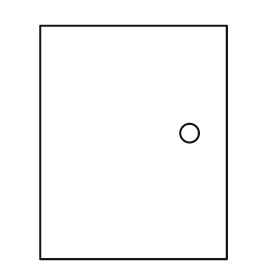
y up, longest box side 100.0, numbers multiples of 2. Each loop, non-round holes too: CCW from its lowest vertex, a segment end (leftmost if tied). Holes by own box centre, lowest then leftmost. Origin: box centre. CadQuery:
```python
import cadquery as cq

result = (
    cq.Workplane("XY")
    .moveTo(-40.0, -50.0)
    .lineTo(40.0, -50.0)
    .lineTo(40.0, 50.0)
    .lineTo(-40.0, 50.0)
    .close()
    .moveTo(24.0, 4.0)
    .circle(4.0)
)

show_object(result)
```